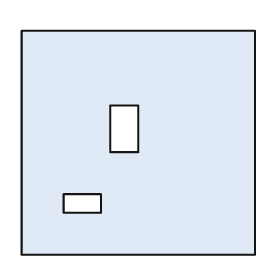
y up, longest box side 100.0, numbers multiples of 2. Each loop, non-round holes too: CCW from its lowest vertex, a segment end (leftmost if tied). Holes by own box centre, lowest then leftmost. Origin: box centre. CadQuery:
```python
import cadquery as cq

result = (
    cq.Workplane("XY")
    .moveTo(-50.0, -48.0)
    .lineTo(50.0, -48.0)
    .lineTo(50.0, 48.0)
    .lineTo(-50.0, 48.0)
    .close()
    .moveTo(-32.0, -30.0)
    .lineTo(-16.0, -30.0)
    .lineTo(-16.0, -22.0)
    .lineTo(-32.0, -22.0)
    .close()
    .moveTo(-12.0, -4.0)
    .lineTo(0.0, -4.0)
    .lineTo(0.0, 16.0)
    .lineTo(-12.0, 16.0)
    .close()
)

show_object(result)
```